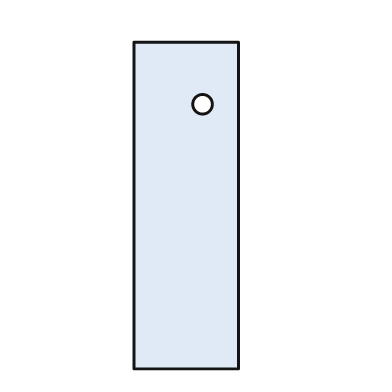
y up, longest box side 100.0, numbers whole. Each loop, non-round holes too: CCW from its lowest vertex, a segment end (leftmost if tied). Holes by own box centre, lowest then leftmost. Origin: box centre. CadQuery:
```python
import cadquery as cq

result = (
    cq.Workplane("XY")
    .moveTo(-16.0, -50.0)
    .lineTo(16.0, -50.0)
    .lineTo(16.0, 50.0)
    .lineTo(-16.0, 50.0)
    .close()
    .moveTo(5.0, 31.0)
    .circle(3.0)
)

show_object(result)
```